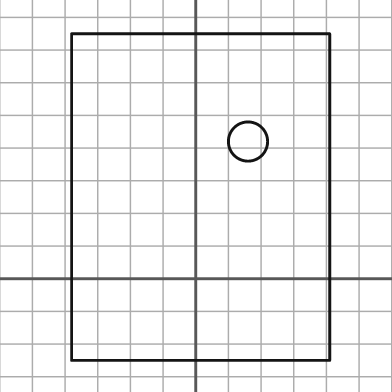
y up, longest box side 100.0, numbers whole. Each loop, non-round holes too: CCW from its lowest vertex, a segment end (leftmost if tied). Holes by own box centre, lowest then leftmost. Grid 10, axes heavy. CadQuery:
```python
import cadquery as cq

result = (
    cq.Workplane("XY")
    .moveTo(-38.0, -25.0)
    .lineTo(41.0, -25.0)
    .lineTo(41.0, 75.0)
    .lineTo(-38.0, 75.0)
    .close()
    .moveTo(16.0, 42.0)
    .circle(6.0)
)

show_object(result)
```